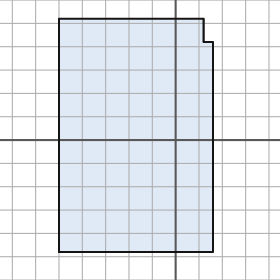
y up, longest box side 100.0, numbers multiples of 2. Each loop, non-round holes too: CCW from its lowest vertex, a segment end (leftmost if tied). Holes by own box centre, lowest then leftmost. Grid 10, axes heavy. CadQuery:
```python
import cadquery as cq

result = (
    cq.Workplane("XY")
    .moveTo(-50.0, -48.0)
    .lineTo(16.0, -48.0)
    .lineTo(16.0, 42.0)
    .lineTo(12.0, 42.0)
    .lineTo(12.0, 52.0)
    .lineTo(-50.0, 52.0)
    .close()
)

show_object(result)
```